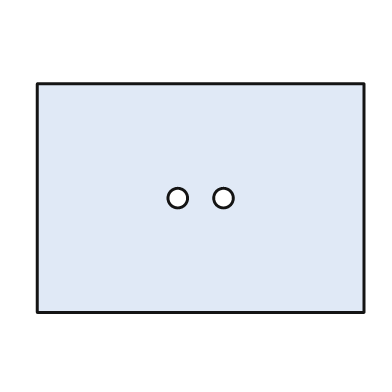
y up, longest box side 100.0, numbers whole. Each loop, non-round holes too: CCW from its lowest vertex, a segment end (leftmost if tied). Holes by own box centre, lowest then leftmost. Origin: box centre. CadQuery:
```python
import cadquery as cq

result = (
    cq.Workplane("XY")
    .moveTo(-50.0, -35.0)
    .lineTo(50.0, -35.0)
    .lineTo(50.0, 35.0)
    .lineTo(-50.0, 35.0)
    .close()
    .moveTo(-7.0, 0.0)
    .circle(3.0)
    .moveTo(7.0, 0.0)
    .circle(3.0)
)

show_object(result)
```